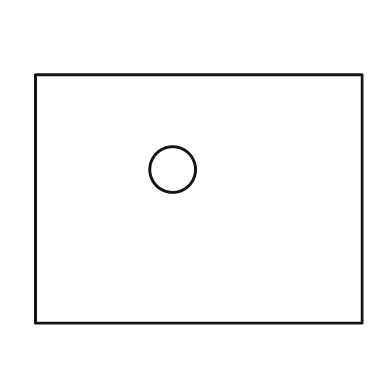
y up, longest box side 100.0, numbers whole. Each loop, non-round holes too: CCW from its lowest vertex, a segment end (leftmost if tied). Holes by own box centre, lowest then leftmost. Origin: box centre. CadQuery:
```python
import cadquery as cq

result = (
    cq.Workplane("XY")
    .moveTo(-50.0, -38.0)
    .lineTo(50.0, -38.0)
    .lineTo(50.0, 38.0)
    .lineTo(-50.0, 38.0)
    .close()
    .moveTo(-8.0, 9.0)
    .circle(7.0)
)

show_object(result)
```